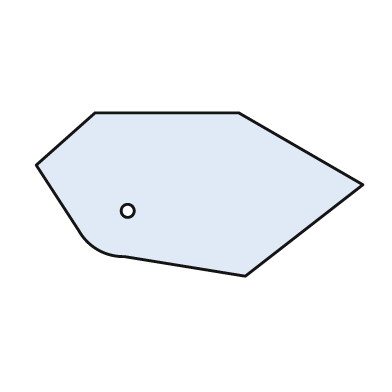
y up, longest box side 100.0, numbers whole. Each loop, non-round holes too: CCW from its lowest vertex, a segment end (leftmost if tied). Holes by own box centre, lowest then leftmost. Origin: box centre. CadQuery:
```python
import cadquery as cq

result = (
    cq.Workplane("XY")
    .moveTo(14.0, -25.0)
    .lineTo(50.0, 3.0)
    .lineTo(12.0, 25.0)
    .lineTo(-32.0, 25.0)
    .lineTo(-50.0, 9.0)
    .lineTo(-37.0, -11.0)
    .threePointArc((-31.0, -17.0), (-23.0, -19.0))
    .close()
    .moveTo(-22.0, -5.0)
    .circle(2.0)
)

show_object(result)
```